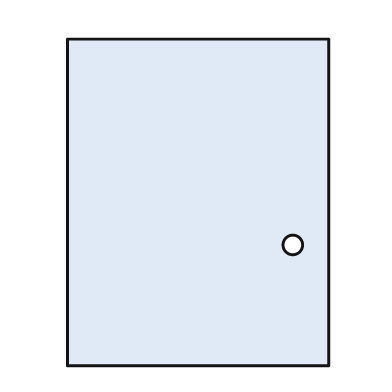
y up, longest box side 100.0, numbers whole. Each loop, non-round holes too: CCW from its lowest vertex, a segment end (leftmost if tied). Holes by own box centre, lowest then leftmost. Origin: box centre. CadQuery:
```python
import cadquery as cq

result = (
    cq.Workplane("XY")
    .moveTo(-40.0, -50.0)
    .lineTo(40.0, -50.0)
    .lineTo(40.0, 50.0)
    .lineTo(-40.0, 50.0)
    .close()
    .moveTo(29.0, -13.0)
    .circle(3.0)
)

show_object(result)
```